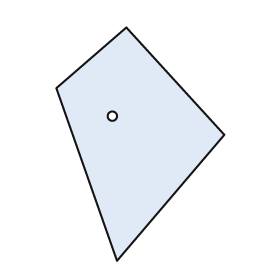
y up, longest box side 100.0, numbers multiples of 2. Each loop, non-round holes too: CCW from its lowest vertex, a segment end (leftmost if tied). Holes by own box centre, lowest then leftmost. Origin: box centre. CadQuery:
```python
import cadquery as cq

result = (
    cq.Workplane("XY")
    .moveTo(-10.0, -50.0)
    .lineTo(36.0, 4.0)
    .lineTo(-6.0, 50.0)
    .lineTo(-36.0, 24.0)
    .close()
    .moveTo(-12.0, 12.0)
    .circle(2.0)
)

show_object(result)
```